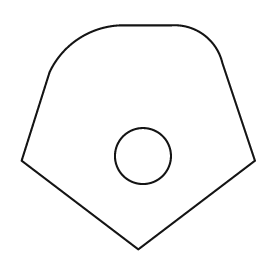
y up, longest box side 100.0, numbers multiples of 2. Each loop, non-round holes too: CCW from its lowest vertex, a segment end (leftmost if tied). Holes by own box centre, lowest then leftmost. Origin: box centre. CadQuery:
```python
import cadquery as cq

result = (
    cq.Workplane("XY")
    .moveTo(0.0, -48.0)
    .lineTo(50.0, -10.0)
    .lineTo(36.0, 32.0)
    .threePointArc((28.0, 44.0), (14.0, 48.0))
    .lineTo(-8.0, 48.0)
    .threePointArc((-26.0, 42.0), (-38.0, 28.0))
    .lineTo(-50.0, -10.0)
    .close()
    .moveTo(2.0, -8.0)
    .circle(12.0)
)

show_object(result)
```